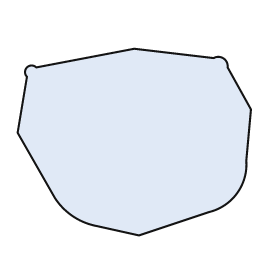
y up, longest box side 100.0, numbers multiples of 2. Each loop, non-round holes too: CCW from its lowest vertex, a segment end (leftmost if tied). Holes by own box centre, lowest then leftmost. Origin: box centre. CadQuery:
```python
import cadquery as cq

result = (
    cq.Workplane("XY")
    .moveTo(2.0, -40.0)
    .lineTo(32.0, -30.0)
    .threePointArc((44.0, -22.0), (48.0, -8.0))
    .lineTo(50.0, 14.0)
    .lineTo(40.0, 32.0)
    .threePointArc((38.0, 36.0), (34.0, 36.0))
    .lineTo(0.0, 40.0)
    .lineTo(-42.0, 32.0)
    .threePointArc((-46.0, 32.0), (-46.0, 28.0))
    .lineTo(-50.0, 4.0)
    .lineTo(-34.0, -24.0)
    .threePointArc((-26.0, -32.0), (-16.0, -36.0))
    .close()
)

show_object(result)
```